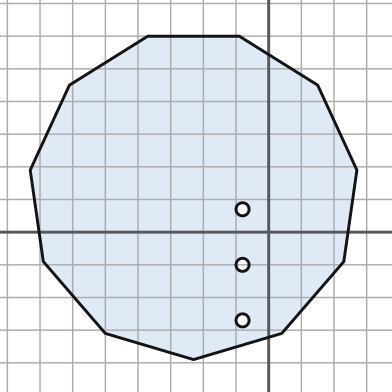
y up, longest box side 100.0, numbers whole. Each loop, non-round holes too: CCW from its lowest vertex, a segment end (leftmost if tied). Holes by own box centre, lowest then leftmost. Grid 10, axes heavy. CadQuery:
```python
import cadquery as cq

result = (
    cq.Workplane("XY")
    .moveTo(-23.0, -39.0)
    .lineTo(4.0, -31.0)
    .lineTo(23.0, -9.0)
    .lineTo(27.0, 19.0)
    .lineTo(15.0, 45.0)
    .lineTo(-9.0, 60.0)
    .lineTo(-37.0, 60.0)
    .lineTo(-61.0, 45.0)
    .lineTo(-73.0, 19.0)
    .lineTo(-69.0, -9.0)
    .lineTo(-50.0, -31.0)
    .close()
    .moveTo(-8.0, -27.0)
    .circle(2.0)
    .moveTo(-8.0, -10.0)
    .circle(2.0)
    .moveTo(-8.0, 7.0)
    .circle(2.0)
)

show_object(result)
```